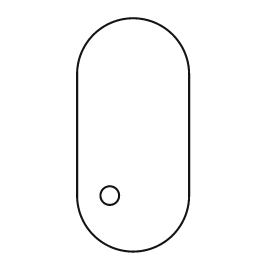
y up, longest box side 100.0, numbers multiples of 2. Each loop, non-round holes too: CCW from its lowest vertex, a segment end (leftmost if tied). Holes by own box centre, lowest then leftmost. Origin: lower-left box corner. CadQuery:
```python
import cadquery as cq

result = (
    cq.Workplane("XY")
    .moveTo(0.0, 24.0)
    .threePointArc((24.0, 0.0), (48.0, 24.0))
    .lineTo(48.0, 76.0)
    .threePointArc((24.0, 100.0), (0.0, 76.0))
    .close()
    .moveTo(14.0, 24.0)
    .circle(4.0)
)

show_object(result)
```